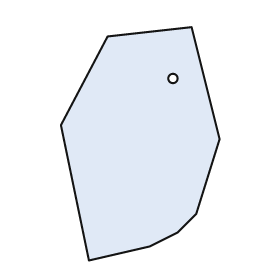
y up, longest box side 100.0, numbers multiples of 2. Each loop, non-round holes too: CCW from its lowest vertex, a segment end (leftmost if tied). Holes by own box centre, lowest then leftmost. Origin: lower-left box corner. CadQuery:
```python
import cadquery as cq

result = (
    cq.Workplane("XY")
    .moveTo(12.0, 0.0)
    .lineTo(38.0, 6.0)
    .lineTo(50.0, 12.0)
    .lineTo(58.0, 20.0)
    .lineTo(68.0, 52.0)
    .lineTo(56.0, 100.0)
    .lineTo(20.0, 96.0)
    .lineTo(0.0, 58.0)
    .close()
    .moveTo(48.0, 78.0)
    .circle(2.0)
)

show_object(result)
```